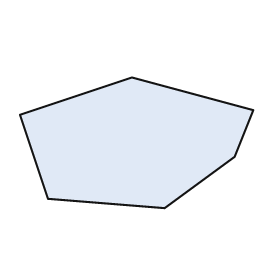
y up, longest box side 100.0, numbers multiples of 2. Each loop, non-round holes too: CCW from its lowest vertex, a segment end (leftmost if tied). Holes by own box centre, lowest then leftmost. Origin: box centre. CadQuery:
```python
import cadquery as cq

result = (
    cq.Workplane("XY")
    .moveTo(12.0, -28.0)
    .lineTo(42.0, -6.0)
    .lineTo(50.0, 14.0)
    .lineTo(-2.0, 28.0)
    .lineTo(-50.0, 12.0)
    .lineTo(-38.0, -24.0)
    .close()
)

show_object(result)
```